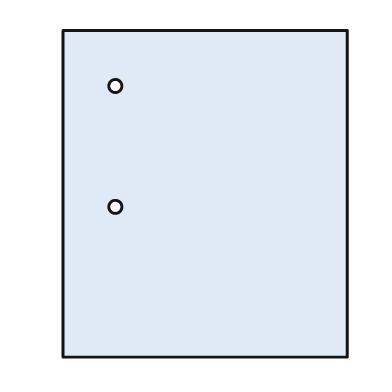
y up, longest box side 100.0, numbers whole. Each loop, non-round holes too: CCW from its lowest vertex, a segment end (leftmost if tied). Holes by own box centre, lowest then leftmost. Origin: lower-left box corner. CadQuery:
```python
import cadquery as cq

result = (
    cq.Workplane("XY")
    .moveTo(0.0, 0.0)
    .lineTo(87.0, 0.0)
    .lineTo(87.0, 100.0)
    .lineTo(0.0, 100.0)
    .close()
    .moveTo(16.0, 46.0)
    .circle(2.0)
    .moveTo(16.0, 83.0)
    .circle(2.0)
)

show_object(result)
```